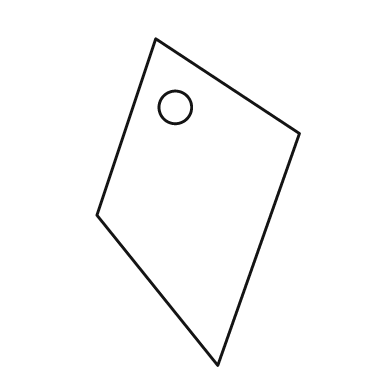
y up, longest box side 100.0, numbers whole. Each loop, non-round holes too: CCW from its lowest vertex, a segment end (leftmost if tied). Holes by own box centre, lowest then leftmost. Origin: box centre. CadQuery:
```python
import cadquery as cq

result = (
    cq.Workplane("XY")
    .moveTo(6.0, -50.0)
    .lineTo(31.0, 21.0)
    .lineTo(-13.0, 50.0)
    .lineTo(-31.0, -4.0)
    .close()
    .moveTo(-7.0, 29.0)
    .circle(5.0)
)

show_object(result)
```